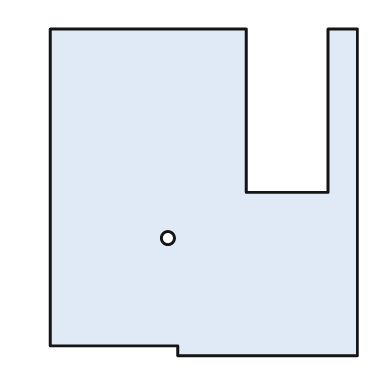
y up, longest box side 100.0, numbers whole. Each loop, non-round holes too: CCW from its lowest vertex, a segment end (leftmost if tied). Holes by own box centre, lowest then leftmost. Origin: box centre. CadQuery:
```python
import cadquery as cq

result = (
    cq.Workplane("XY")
    .moveTo(-8.0, -50.0)
    .lineTo(47.0, -50.0)
    .lineTo(47.0, 50.0)
    .lineTo(38.0, 50.0)
    .lineTo(38.0, 0.0)
    .lineTo(13.0, 0.0)
    .lineTo(13.0, 50.0)
    .lineTo(-47.0, 50.0)
    .lineTo(-47.0, -47.0)
    .lineTo(-8.0, -47.0)
    .close()
    .moveTo(-11.0, -14.0)
    .circle(2.0)
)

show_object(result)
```